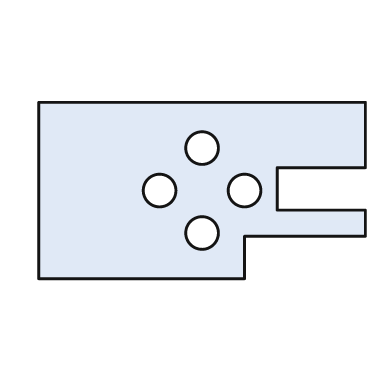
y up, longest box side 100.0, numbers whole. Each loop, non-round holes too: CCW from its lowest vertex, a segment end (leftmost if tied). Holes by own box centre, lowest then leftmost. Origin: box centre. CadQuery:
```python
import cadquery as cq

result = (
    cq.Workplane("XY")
    .moveTo(-50.0, -27.0)
    .lineTo(13.0, -27.0)
    .lineTo(13.0, -14.0)
    .lineTo(50.0, -14.0)
    .lineTo(50.0, -6.0)
    .lineTo(23.0, -6.0)
    .lineTo(23.0, 7.0)
    .lineTo(50.0, 7.0)
    .lineTo(50.0, 27.0)
    .lineTo(-50.0, 27.0)
    .close()
    .moveTo(0.0, -13.0)
    .circle(5.0)
    .moveTo(-13.0, 0.0)
    .circle(5.0)
    .moveTo(13.0, 0.0)
    .circle(5.0)
    .moveTo(0.0, 13.0)
    .circle(5.0)
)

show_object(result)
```